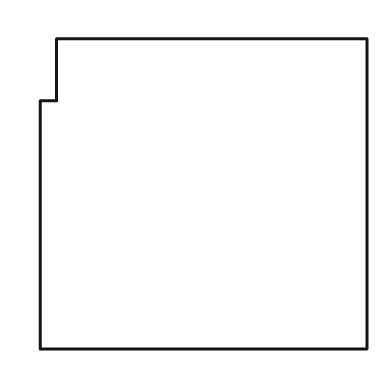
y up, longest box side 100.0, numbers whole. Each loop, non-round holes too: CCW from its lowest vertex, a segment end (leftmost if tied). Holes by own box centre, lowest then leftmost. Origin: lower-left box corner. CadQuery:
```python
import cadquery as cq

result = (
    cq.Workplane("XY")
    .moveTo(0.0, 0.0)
    .lineTo(100.0, 0.0)
    .lineTo(100.0, 95.0)
    .lineTo(5.0, 95.0)
    .lineTo(5.0, 76.0)
    .lineTo(0.0, 76.0)
    .close()
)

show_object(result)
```